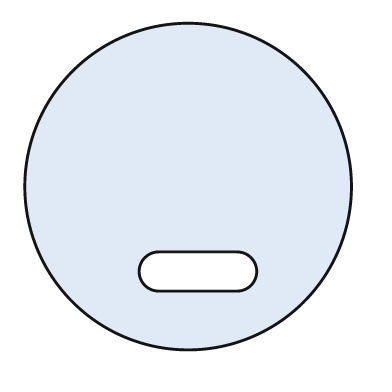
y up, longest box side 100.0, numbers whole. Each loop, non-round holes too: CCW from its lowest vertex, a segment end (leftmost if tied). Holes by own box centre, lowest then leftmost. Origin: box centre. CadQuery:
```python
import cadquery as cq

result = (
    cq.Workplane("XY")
    .moveTo(0.0, 0.0)
    .circle(50.0)
    .moveTo(-9.0, -32.0)
    .lineTo(15.0, -32.0)
    .threePointArc((21.0, -26.0), (15.0, -20.0))
    .lineTo(-9.0, -20.0)
    .threePointArc((-15.0, -26.0), (-9.0, -32.0))
    .close()
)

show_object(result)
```